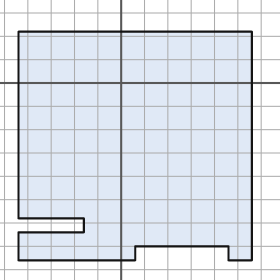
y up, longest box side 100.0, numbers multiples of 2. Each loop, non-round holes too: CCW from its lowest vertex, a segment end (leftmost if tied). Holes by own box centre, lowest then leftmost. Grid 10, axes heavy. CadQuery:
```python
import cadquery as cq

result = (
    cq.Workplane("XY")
    .moveTo(-44.0, -76.0)
    .lineTo(6.0, -76.0)
    .lineTo(6.0, -70.0)
    .lineTo(46.0, -70.0)
    .lineTo(46.0, -76.0)
    .lineTo(56.0, -76.0)
    .lineTo(56.0, 22.0)
    .lineTo(-44.0, 22.0)
    .lineTo(-44.0, -58.0)
    .lineTo(-16.0, -58.0)
    .lineTo(-16.0, -64.0)
    .lineTo(-44.0, -64.0)
    .close()
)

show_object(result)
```